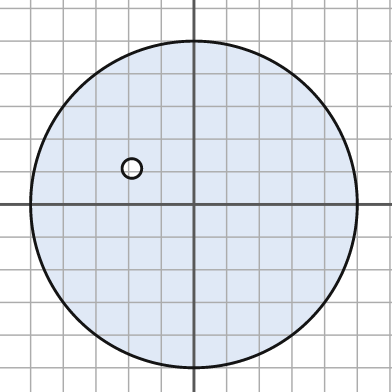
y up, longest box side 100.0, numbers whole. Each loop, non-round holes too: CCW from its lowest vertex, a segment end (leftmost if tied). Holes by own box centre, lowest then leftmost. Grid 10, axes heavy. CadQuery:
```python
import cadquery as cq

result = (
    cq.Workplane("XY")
    .moveTo(0.0, 0.0)
    .circle(50.0)
    .moveTo(-19.0, 11.0)
    .circle(3.0)
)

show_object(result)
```